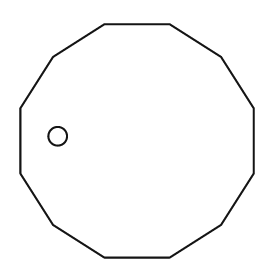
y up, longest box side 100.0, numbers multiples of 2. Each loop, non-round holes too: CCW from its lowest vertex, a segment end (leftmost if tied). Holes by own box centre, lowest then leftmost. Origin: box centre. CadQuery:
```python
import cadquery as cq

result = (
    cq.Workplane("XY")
    .moveTo(-14.0, -50.0)
    .lineTo(14.0, -50.0)
    .lineTo(36.0, -36.0)
    .lineTo(50.0, -14.0)
    .lineTo(50.0, 14.0)
    .lineTo(36.0, 36.0)
    .lineTo(14.0, 50.0)
    .lineTo(-14.0, 50.0)
    .lineTo(-36.0, 36.0)
    .lineTo(-50.0, 14.0)
    .lineTo(-50.0, -14.0)
    .lineTo(-36.0, -36.0)
    .close()
    .moveTo(-34.0, 2.0)
    .circle(4.0)
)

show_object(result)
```